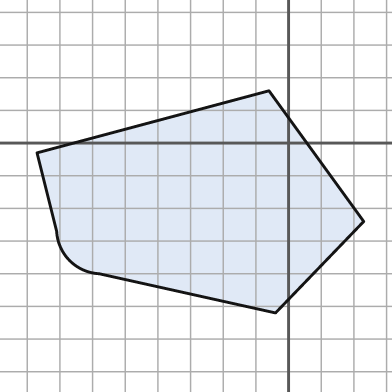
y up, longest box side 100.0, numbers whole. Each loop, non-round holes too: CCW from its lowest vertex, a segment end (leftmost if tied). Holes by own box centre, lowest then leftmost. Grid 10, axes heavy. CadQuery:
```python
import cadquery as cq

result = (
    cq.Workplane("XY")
    .moveTo(-4.0, -52.0)
    .lineTo(23.0, -24.0)
    .lineTo(-6.0, 16.0)
    .lineTo(-77.0, -3.0)
    .lineTo(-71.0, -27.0)
    .threePointArc((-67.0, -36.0), (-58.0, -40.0))
    .close()
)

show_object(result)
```